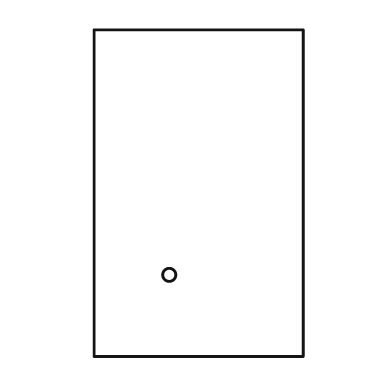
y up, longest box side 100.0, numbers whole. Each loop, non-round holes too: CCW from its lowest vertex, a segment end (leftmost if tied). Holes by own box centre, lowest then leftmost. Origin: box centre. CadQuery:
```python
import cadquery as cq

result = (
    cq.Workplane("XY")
    .moveTo(-32.0, -50.0)
    .lineTo(32.0, -50.0)
    .lineTo(32.0, 50.0)
    .lineTo(-32.0, 50.0)
    .close()
    .moveTo(-9.0, -25.0)
    .circle(2.0)
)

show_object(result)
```